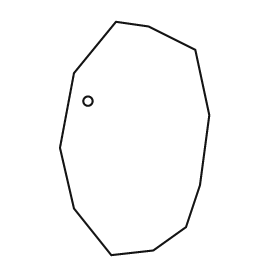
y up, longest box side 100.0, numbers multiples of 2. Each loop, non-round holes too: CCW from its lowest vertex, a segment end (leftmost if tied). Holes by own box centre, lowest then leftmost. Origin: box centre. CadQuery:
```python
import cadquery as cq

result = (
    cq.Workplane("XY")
    .moveTo(-10.0, -50.0)
    .lineTo(8.0, -48.0)
    .lineTo(22.0, -38.0)
    .lineTo(28.0, -20.0)
    .lineTo(32.0, 10.0)
    .lineTo(26.0, 38.0)
    .lineTo(6.0, 48.0)
    .lineTo(-8.0, 50.0)
    .lineTo(-26.0, 28.0)
    .lineTo(-32.0, -4.0)
    .lineTo(-26.0, -30.0)
    .close()
    .moveTo(-20.0, 16.0)
    .circle(2.0)
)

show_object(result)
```